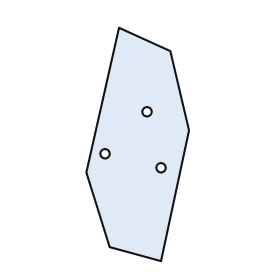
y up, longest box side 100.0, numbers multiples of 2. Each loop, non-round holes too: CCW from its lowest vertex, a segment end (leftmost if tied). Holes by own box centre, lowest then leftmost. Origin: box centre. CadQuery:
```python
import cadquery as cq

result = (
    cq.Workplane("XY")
    .moveTo(10.0, -50.0)
    .lineTo(22.0, 6.0)
    .lineTo(14.0, 40.0)
    .lineTo(-8.0, 50.0)
    .lineTo(-22.0, -12.0)
    .lineTo(-12.0, -44.0)
    .close()
    .moveTo(10.0, -10.0)
    .circle(2.0)
    .moveTo(-14.0, -4.0)
    .circle(2.0)
    .moveTo(4.0, 14.0)
    .circle(2.0)
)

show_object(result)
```